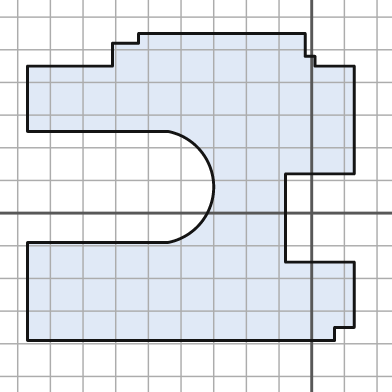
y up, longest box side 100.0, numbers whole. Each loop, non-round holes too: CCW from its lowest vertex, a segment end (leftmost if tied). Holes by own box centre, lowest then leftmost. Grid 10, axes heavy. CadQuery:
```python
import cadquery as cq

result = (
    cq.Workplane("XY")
    .moveTo(-87.0, -39.0)
    .lineTo(7.0, -39.0)
    .lineTo(7.0, -35.0)
    .lineTo(13.0, -35.0)
    .lineTo(13.0, -15.0)
    .lineTo(-8.0, -15.0)
    .lineTo(-8.0, 12.0)
    .lineTo(13.0, 12.0)
    .lineTo(13.0, 45.0)
    .lineTo(1.0, 45.0)
    .lineTo(1.0, 48.0)
    .lineTo(-2.0, 48.0)
    .lineTo(-2.0, 55.0)
    .lineTo(-53.0, 55.0)
    .lineTo(-53.0, 52.0)
    .lineTo(-61.0, 52.0)
    .lineTo(-61.0, 45.0)
    .lineTo(-87.0, 45.0)
    .lineTo(-87.0, 25.0)
    .lineTo(-44.0, 25.0)
    .threePointArc((-30.0, 8.0), (-44.0, -9.0))
    .lineTo(-87.0, -9.0)
    .close()
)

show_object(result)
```